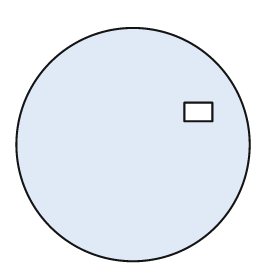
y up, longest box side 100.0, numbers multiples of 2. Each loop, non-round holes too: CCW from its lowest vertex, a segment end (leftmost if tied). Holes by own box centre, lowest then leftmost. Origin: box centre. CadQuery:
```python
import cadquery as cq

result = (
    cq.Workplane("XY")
    .moveTo(0.0, 0.0)
    .circle(50.0)
    .moveTo(22.0, 10.0)
    .lineTo(34.0, 10.0)
    .lineTo(34.0, 18.0)
    .lineTo(22.0, 18.0)
    .close()
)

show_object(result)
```